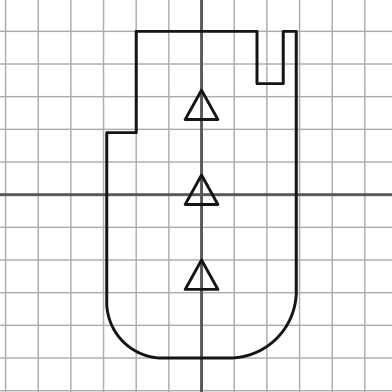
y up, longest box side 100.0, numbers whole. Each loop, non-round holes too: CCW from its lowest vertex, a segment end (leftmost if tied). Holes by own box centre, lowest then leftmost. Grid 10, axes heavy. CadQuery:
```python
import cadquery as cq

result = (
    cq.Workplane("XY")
    .moveTo(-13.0, -50.0)
    .lineTo(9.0, -50.0)
    .threePointArc((23.0, -44.0), (29.0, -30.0))
    .lineTo(29.0, 50.0)
    .lineTo(25.0, 50.0)
    .lineTo(25.0, 34.0)
    .lineTo(17.0, 34.0)
    .lineTo(17.0, 50.0)
    .lineTo(-20.0, 50.0)
    .lineTo(-20.0, 19.0)
    .lineTo(-29.0, 19.0)
    .lineTo(-29.0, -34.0)
    .threePointArc((-24.0, -45.0), (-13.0, -50.0))
    .close()
    .moveTo(-5.0, -29.0)
    .lineTo(5.0, -29.0)
    .lineTo(0.0, -20.0)
    .close()
    .moveTo(-5.0, -3.0)
    .lineTo(5.0, -3.0)
    .lineTo(0.0, 6.0)
    .close()
    .moveTo(-5.0, 23.0)
    .lineTo(5.0, 23.0)
    .lineTo(0.0, 32.0)
    .close()
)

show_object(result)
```